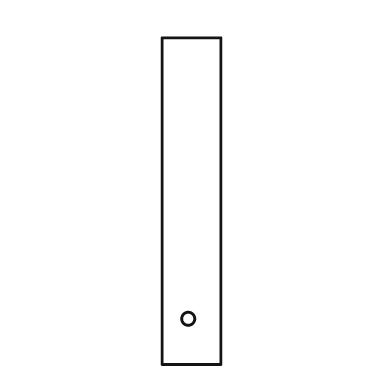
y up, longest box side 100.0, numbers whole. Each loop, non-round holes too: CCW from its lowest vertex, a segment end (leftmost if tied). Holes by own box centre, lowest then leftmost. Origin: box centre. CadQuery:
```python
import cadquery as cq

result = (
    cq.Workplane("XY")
    .moveTo(-9.0, -50.0)
    .lineTo(9.0, -50.0)
    .lineTo(9.0, 50.0)
    .lineTo(-9.0, 50.0)
    .close()
    .moveTo(-1.0, -36.0)
    .circle(2.0)
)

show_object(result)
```